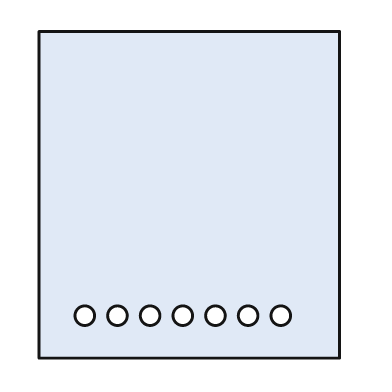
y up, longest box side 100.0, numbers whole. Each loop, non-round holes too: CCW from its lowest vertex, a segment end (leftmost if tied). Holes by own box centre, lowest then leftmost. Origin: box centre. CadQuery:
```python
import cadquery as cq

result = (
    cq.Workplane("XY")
    .moveTo(-46.0, -50.0)
    .lineTo(46.0, -50.0)
    .lineTo(46.0, 50.0)
    .lineTo(-46.0, 50.0)
    .close()
    .moveTo(-32.0, -37.0)
    .circle(3.0)
    .moveTo(-22.0, -37.0)
    .circle(3.0)
    .moveTo(-12.0, -37.0)
    .circle(3.0)
    .moveTo(-2.0, -37.0)
    .circle(3.0)
    .moveTo(8.0, -37.0)
    .circle(3.0)
    .moveTo(18.0, -37.0)
    .circle(3.0)
    .moveTo(28.0, -37.0)
    .circle(3.0)
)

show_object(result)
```